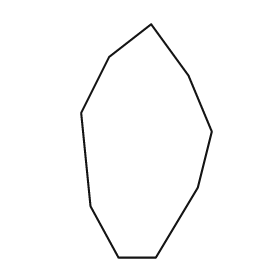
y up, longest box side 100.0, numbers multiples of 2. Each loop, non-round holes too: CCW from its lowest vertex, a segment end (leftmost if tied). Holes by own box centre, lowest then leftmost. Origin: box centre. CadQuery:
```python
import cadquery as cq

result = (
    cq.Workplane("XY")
    .moveTo(-12.0, -50.0)
    .lineTo(4.0, -50.0)
    .lineTo(22.0, -20.0)
    .lineTo(28.0, 4.0)
    .lineTo(18.0, 28.0)
    .lineTo(2.0, 50.0)
    .lineTo(-16.0, 36.0)
    .lineTo(-28.0, 12.0)
    .lineTo(-24.0, -28.0)
    .close()
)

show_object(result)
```